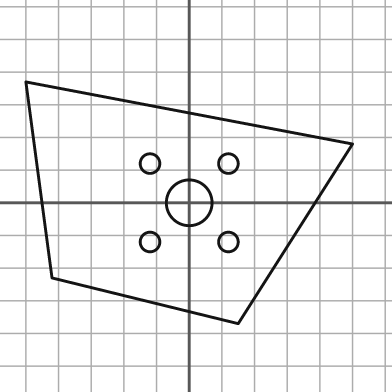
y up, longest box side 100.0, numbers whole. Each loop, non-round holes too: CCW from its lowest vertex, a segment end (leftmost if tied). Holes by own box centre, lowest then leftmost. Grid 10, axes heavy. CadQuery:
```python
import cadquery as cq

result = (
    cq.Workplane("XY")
    .moveTo(15.0, -37.0)
    .lineTo(50.0, 18.0)
    .lineTo(-50.0, 37.0)
    .lineTo(-42.0, -23.0)
    .close()
    .moveTo(-12.0, -12.0)
    .circle(3.0)
    .moveTo(12.0, -12.0)
    .circle(3.0)
    .moveTo(0.0, 0.0)
    .circle(7.0)
    .moveTo(-12.0, 12.0)
    .circle(3.0)
    .moveTo(12.0, 12.0)
    .circle(3.0)
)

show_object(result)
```